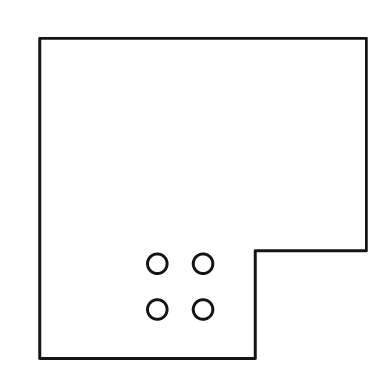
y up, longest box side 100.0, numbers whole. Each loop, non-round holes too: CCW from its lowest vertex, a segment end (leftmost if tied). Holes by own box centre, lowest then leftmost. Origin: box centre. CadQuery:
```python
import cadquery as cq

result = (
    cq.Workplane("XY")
    .moveTo(-50.0, -49.0)
    .lineTo(16.0, -49.0)
    .lineTo(16.0, -16.0)
    .lineTo(50.0, -16.0)
    .lineTo(50.0, 49.0)
    .lineTo(-50.0, 49.0)
    .close()
    .moveTo(-14.0, -34.0)
    .circle(3.0)
    .moveTo(0.0, -34.0)
    .circle(3.0)
    .moveTo(-14.0, -20.0)
    .circle(3.0)
    .moveTo(0.0, -20.0)
    .circle(3.0)
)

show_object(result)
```